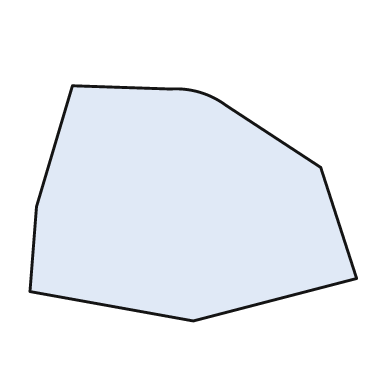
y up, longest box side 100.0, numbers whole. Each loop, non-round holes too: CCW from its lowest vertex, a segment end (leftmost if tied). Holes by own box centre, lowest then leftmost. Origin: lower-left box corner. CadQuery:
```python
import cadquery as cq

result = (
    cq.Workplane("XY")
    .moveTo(50.0, 0.0)
    .lineTo(100.0, 13.0)
    .lineTo(89.0, 47.0)
    .lineTo(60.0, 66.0)
    .threePointArc((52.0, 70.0), (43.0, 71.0))
    .lineTo(13.0, 72.0)
    .lineTo(2.0, 35.0)
    .lineTo(0.0, 9.0)
    .close()
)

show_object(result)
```